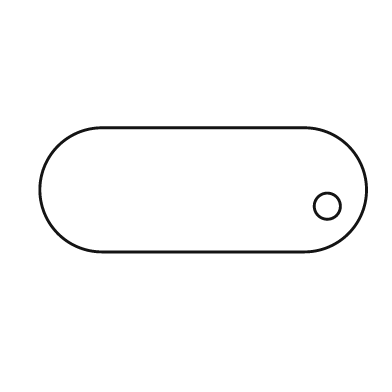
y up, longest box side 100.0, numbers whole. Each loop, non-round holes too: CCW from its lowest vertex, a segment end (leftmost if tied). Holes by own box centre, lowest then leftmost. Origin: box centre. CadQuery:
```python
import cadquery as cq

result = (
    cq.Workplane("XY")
    .moveTo(-31.0, -19.0)
    .lineTo(31.0, -19.0)
    .threePointArc((50.0, 0.0), (31.0, 19.0))
    .lineTo(-31.0, 19.0)
    .threePointArc((-50.0, 0.0), (-31.0, -19.0))
    .close()
    .moveTo(38.0, -5.0)
    .circle(4.0)
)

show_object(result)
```